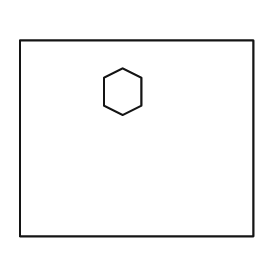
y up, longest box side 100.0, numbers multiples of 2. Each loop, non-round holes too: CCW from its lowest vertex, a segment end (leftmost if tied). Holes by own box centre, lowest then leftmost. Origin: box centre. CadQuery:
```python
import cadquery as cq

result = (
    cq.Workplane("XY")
    .moveTo(-50.0, -42.0)
    .lineTo(50.0, -42.0)
    .lineTo(50.0, 42.0)
    .lineTo(-50.0, 42.0)
    .close()
    .moveTo(-6.0, 10.0)
    .lineTo(2.0, 14.0)
    .lineTo(2.0, 26.0)
    .lineTo(-6.0, 30.0)
    .lineTo(-14.0, 26.0)
    .lineTo(-14.0, 14.0)
    .close()
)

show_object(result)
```